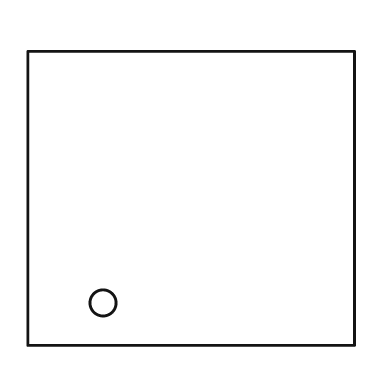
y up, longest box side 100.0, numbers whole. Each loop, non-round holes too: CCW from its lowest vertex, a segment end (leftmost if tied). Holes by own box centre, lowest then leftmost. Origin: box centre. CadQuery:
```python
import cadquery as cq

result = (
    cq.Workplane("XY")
    .moveTo(-50.0, -45.0)
    .lineTo(50.0, -45.0)
    .lineTo(50.0, 45.0)
    .lineTo(-50.0, 45.0)
    .close()
    .moveTo(-27.0, -32.0)
    .circle(4.0)
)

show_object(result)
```